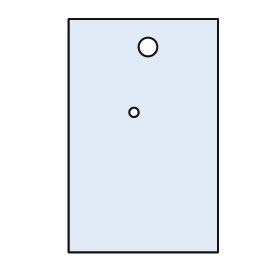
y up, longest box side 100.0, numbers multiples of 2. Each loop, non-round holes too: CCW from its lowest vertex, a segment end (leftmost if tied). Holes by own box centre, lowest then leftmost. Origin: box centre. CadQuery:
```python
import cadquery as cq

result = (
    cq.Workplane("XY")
    .moveTo(-32.0, -50.0)
    .lineTo(32.0, -50.0)
    .lineTo(32.0, 50.0)
    .lineTo(-32.0, 50.0)
    .close()
    .moveTo(-4.0, 10.0)
    .circle(2.0)
    .moveTo(2.0, 38.0)
    .circle(4.0)
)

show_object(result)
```